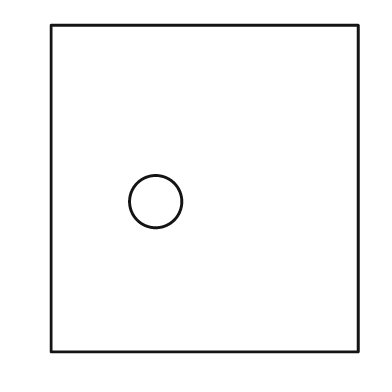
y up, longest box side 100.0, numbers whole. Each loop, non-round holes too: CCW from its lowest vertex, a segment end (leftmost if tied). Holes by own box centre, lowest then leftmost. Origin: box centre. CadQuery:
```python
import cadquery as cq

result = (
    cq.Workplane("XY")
    .moveTo(-47.0, -50.0)
    .lineTo(47.0, -50.0)
    .lineTo(47.0, 50.0)
    .lineTo(-47.0, 50.0)
    .close()
    .moveTo(-15.0, -4.0)
    .circle(8.0)
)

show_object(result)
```